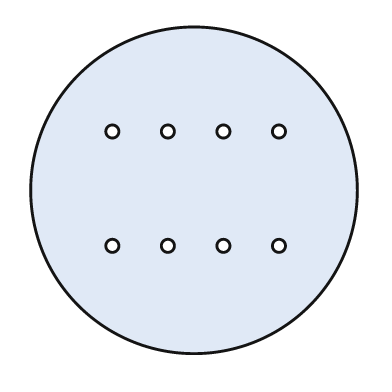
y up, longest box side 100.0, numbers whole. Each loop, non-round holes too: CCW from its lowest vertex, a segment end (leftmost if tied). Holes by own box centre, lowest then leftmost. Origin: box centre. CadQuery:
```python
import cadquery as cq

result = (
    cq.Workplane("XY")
    .moveTo(0.0, 0.0)
    .circle(50.0)
    .moveTo(-25.0, -17.0)
    .circle(2.0)
    .moveTo(-8.0, -17.0)
    .circle(2.0)
    .moveTo(9.0, -17.0)
    .circle(2.0)
    .moveTo(26.0, -17.0)
    .circle(2.0)
    .moveTo(-25.0, 18.0)
    .circle(2.0)
    .moveTo(-8.0, 18.0)
    .circle(2.0)
    .moveTo(9.0, 18.0)
    .circle(2.0)
    .moveTo(26.0, 18.0)
    .circle(2.0)
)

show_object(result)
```